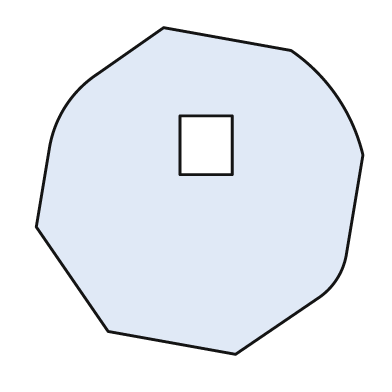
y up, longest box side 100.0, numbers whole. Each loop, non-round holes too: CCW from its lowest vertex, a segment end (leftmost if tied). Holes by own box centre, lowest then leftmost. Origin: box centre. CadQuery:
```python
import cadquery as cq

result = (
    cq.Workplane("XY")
    .moveTo(11.0, -50.0)
    .lineTo(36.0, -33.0)
    .threePointArc((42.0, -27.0), (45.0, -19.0))
    .lineTo(50.0, 11.0)
    .threePointArc((42.0, 29.0), (28.0, 43.0))
    .lineTo(-11.0, 50.0)
    .lineTo(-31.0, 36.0)
    .threePointArc((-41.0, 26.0), (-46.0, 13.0))
    .lineTo(-50.0, -11.0)
    .lineTo(-28.0, -43.0)
    .close()
    .moveTo(-6.0, 5.0)
    .lineTo(10.0, 5.0)
    .lineTo(10.0, 23.0)
    .lineTo(-6.0, 23.0)
    .close()
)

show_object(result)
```